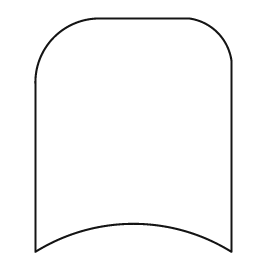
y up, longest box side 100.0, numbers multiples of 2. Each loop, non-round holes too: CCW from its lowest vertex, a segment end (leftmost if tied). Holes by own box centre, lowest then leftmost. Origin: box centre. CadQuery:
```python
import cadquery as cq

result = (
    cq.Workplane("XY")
    .moveTo(-42.0, -50.0)
    .threePointArc((0.0, -38.0), (42.0, -50.0))
    .lineTo(42.0, 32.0)
    .threePointArc((36.0, 44.0), (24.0, 50.0))
    .lineTo(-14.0, 50.0)
    .threePointArc((-34.0, 42.0), (-42.0, 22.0))
    .close()
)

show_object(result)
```